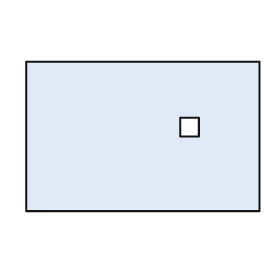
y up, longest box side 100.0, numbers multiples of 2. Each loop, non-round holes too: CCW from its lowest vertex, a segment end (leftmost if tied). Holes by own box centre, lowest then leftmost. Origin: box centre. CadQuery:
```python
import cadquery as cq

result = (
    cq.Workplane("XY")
    .moveTo(-50.0, -32.0)
    .lineTo(50.0, -32.0)
    .lineTo(50.0, 32.0)
    .lineTo(-50.0, 32.0)
    .close()
    .moveTo(16.0, 0.0)
    .lineTo(24.0, 0.0)
    .lineTo(24.0, 8.0)
    .lineTo(16.0, 8.0)
    .close()
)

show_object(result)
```